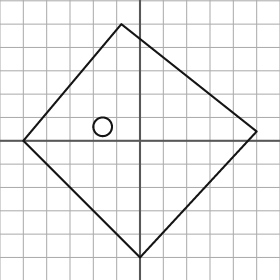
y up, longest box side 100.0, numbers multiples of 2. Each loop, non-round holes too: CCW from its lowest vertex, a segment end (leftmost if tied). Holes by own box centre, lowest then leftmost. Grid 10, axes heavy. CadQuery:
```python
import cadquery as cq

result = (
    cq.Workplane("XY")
    .moveTo(0.0, -50.0)
    .lineTo(50.0, 4.0)
    .lineTo(-8.0, 50.0)
    .lineTo(-50.0, 0.0)
    .close()
    .moveTo(-16.0, 6.0)
    .circle(4.0)
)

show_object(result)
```